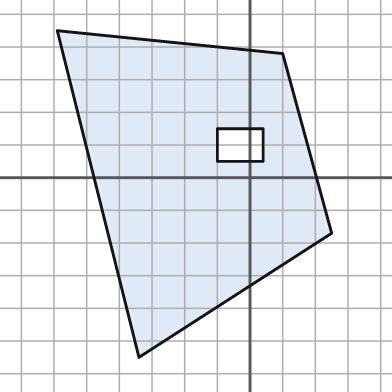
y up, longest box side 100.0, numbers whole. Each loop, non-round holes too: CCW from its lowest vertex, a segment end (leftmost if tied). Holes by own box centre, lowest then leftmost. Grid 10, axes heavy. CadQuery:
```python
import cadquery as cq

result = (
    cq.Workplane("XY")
    .moveTo(-34.0, -55.0)
    .lineTo(25.0, -17.0)
    .lineTo(10.0, 38.0)
    .lineTo(-59.0, 45.0)
    .close()
    .moveTo(-10.0, 5.0)
    .lineTo(4.0, 5.0)
    .lineTo(4.0, 15.0)
    .lineTo(-10.0, 15.0)
    .close()
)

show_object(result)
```